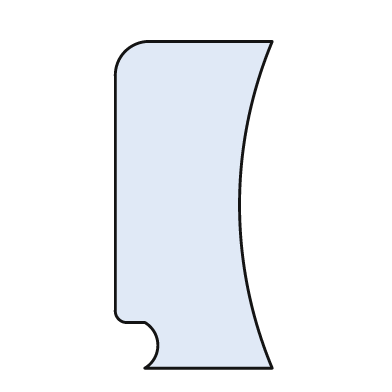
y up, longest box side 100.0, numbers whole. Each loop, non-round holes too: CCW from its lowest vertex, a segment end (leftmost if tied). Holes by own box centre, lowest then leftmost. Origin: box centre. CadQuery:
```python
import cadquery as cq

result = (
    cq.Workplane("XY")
    .moveTo(-15.0, -50.0)
    .lineTo(24.0, -50.0)
    .threePointArc((14.0, 0.0), (24.0, 50.0))
    .lineTo(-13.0, 50.0)
    .threePointArc((-21.0, 47.0), (-24.0, 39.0))
    .lineTo(-24.0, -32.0)
    .threePointArc((-23.0, -35.0), (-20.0, -36.0))
    .lineTo(-15.0, -36.0)
    .threePointArc((-11.0, -43.0), (-15.0, -50.0))
    .close()
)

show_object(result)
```